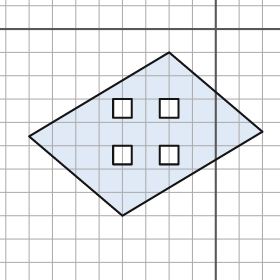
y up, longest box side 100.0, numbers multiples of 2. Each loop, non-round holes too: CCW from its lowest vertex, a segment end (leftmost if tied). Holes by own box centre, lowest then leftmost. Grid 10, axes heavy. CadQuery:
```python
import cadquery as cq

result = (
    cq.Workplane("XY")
    .moveTo(-40.0, -80.0)
    .lineTo(20.0, -44.0)
    .lineTo(-20.0, -10.0)
    .lineTo(-80.0, -46.0)
    .close()
    .moveTo(-44.0, -58.0)
    .lineTo(-36.0, -58.0)
    .lineTo(-36.0, -50.0)
    .lineTo(-44.0, -50.0)
    .close()
    .moveTo(-24.0, -58.0)
    .lineTo(-16.0, -58.0)
    .lineTo(-16.0, -50.0)
    .lineTo(-24.0, -50.0)
    .close()
    .moveTo(-44.0, -38.0)
    .lineTo(-36.0, -38.0)
    .lineTo(-36.0, -30.0)
    .lineTo(-44.0, -30.0)
    .close()
    .moveTo(-24.0, -38.0)
    .lineTo(-16.0, -38.0)
    .lineTo(-16.0, -30.0)
    .lineTo(-24.0, -30.0)
    .close()
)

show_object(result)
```